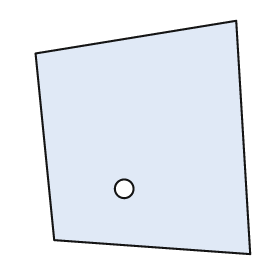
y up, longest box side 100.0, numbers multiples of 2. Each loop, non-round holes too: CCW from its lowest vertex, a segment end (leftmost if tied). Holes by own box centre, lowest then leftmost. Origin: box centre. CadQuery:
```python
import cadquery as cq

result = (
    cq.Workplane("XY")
    .moveTo(46.0, -50.0)
    .lineTo(40.0, 50.0)
    .lineTo(-46.0, 36.0)
    .lineTo(-38.0, -44.0)
    .close()
    .moveTo(-8.0, -22.0)
    .circle(4.0)
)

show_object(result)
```